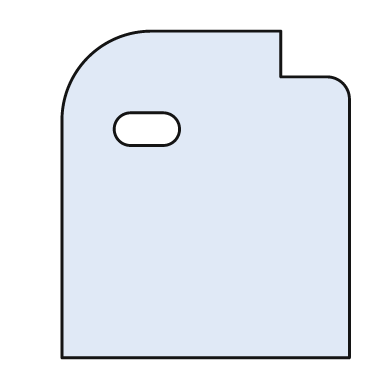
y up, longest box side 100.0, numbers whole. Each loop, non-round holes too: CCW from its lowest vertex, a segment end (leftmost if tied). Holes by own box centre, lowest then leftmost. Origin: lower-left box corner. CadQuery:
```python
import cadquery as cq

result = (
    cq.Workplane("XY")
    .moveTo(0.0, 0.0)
    .lineTo(88.0, 0.0)
    .lineTo(88.0, 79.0)
    .threePointArc((86.0, 84.0), (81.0, 86.0))
    .lineTo(67.0, 86.0)
    .lineTo(67.0, 100.0)
    .lineTo(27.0, 100.0)
    .threePointArc((8.0, 92.0), (0.0, 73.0))
    .close()
    .moveTo(21.0, 65.0)
    .lineTo(31.0, 65.0)
    .threePointArc((36.0, 70.0), (31.0, 75.0))
    .lineTo(21.0, 75.0)
    .threePointArc((16.0, 70.0), (21.0, 65.0))
    .close()
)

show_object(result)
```